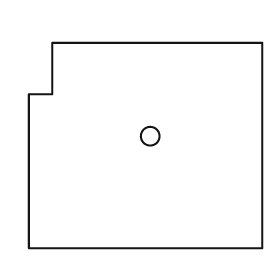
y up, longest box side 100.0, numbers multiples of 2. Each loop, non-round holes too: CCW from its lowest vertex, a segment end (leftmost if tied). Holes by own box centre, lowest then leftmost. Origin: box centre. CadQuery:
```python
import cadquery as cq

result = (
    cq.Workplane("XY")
    .moveTo(-50.0, -44.0)
    .lineTo(50.0, -44.0)
    .lineTo(50.0, 44.0)
    .lineTo(-40.0, 44.0)
    .lineTo(-40.0, 22.0)
    .lineTo(-50.0, 22.0)
    .close()
    .moveTo(2.0, 4.0)
    .circle(4.0)
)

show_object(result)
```